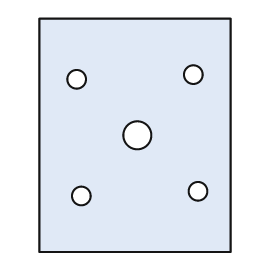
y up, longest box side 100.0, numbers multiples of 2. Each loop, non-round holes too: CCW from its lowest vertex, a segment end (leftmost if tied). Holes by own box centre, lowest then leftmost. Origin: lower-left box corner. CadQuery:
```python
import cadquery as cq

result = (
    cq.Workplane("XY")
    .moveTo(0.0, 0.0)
    .lineTo(82.0, 0.0)
    .lineTo(82.0, 100.0)
    .lineTo(0.0, 100.0)
    .close()
    .moveTo(18.0, 24.0)
    .circle(4.0)
    .moveTo(68.0, 26.0)
    .circle(4.0)
    .moveTo(42.0, 50.0)
    .circle(6.0)
    .moveTo(16.0, 74.0)
    .circle(4.0)
    .moveTo(66.0, 76.0)
    .circle(4.0)
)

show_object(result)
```